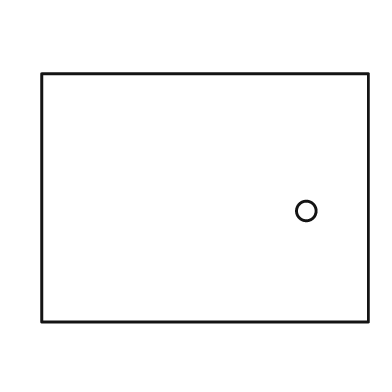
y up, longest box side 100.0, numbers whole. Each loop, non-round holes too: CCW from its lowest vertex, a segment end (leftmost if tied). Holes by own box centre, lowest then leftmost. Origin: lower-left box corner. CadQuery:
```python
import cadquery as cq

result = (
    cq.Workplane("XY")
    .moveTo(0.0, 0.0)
    .lineTo(100.0, 0.0)
    .lineTo(100.0, 76.0)
    .lineTo(0.0, 76.0)
    .close()
    .moveTo(81.0, 34.0)
    .circle(3.0)
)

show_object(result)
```